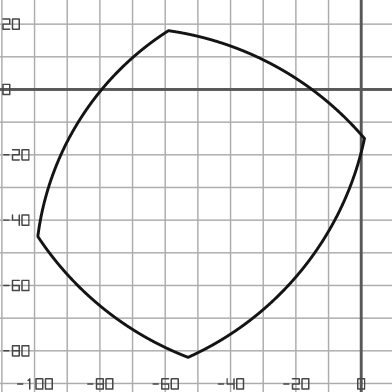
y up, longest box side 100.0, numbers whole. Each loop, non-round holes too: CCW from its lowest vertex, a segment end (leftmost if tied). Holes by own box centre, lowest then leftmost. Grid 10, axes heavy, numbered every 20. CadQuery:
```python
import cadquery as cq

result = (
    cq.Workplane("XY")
    .moveTo(-53.0, -82.0)
    .threePointArc((-18.0, -55.0), (1.0, -15.0))
    .threePointArc((-26.0, 7.0), (-59.0, 18.0))
    .threePointArc((-86.0, -9.0), (-99.0, -45.0))
    .threePointArc((-79.0, -67.0), (-53.0, -82.0))
    .close()
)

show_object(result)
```